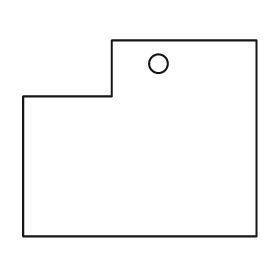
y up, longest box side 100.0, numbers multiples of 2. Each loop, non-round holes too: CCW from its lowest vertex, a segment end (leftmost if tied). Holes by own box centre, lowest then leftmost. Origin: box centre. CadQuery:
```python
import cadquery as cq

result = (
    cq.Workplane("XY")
    .moveTo(-50.0, -42.0)
    .lineTo(50.0, -42.0)
    .lineTo(50.0, 42.0)
    .lineTo(-12.0, 42.0)
    .lineTo(-12.0, 18.0)
    .lineTo(-50.0, 18.0)
    .close()
    .moveTo(8.0, 32.0)
    .circle(4.0)
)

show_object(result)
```